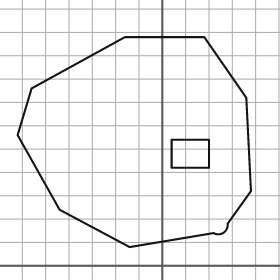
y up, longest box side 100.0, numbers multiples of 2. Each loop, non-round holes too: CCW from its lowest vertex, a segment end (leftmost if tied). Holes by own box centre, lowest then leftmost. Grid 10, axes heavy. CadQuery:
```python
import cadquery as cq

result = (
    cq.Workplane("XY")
    .moveTo(-14.0, 8.0)
    .lineTo(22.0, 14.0)
    .threePointArc((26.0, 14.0), (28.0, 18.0))
    .lineTo(38.0, 32.0)
    .lineTo(36.0, 72.0)
    .lineTo(18.0, 98.0)
    .lineTo(-16.0, 98.0)
    .lineTo(-56.0, 76.0)
    .lineTo(-62.0, 56.0)
    .lineTo(-44.0, 24.0)
    .close()
    .moveTo(4.0, 42.0)
    .lineTo(20.0, 42.0)
    .lineTo(20.0, 54.0)
    .lineTo(4.0, 54.0)
    .close()
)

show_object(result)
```